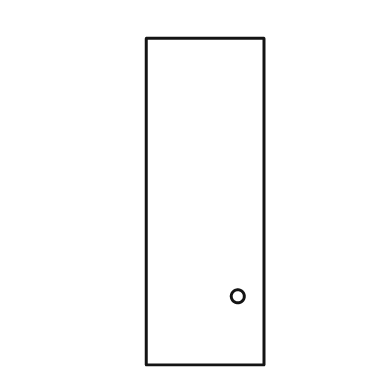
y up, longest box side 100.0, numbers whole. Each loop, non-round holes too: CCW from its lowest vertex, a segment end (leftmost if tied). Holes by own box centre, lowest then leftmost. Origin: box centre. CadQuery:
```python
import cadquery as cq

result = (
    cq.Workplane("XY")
    .moveTo(-18.0, -50.0)
    .lineTo(18.0, -50.0)
    .lineTo(18.0, 50.0)
    .lineTo(-18.0, 50.0)
    .close()
    .moveTo(10.0, -29.0)
    .circle(2.0)
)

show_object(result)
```